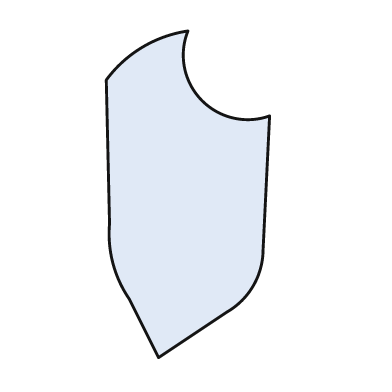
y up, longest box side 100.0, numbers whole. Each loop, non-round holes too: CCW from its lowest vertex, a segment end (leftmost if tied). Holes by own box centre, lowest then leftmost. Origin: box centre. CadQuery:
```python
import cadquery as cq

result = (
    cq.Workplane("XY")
    .moveTo(-9.0, -50.0)
    .lineTo(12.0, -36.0)
    .threePointArc((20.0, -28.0), (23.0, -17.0))
    .lineTo(25.0, 24.0)
    .threePointArc((4.0, 29.0), (0.0, 50.0))
    .threePointArc((-14.0, 45.0), (-25.0, 35.0))
    .lineTo(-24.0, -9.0)
    .threePointArc((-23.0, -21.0), (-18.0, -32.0))
    .close()
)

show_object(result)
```